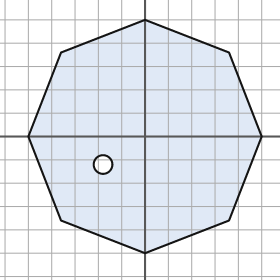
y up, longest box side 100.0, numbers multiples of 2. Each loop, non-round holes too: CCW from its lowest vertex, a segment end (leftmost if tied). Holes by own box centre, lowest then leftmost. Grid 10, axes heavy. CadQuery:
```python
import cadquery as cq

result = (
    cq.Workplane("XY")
    .moveTo(0.0, -50.0)
    .lineTo(36.0, -36.0)
    .lineTo(50.0, 0.0)
    .lineTo(36.0, 36.0)
    .lineTo(0.0, 50.0)
    .lineTo(-36.0, 36.0)
    .lineTo(-50.0, 0.0)
    .lineTo(-36.0, -36.0)
    .close()
    .moveTo(-18.0, -12.0)
    .circle(4.0)
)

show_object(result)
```